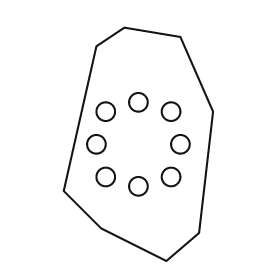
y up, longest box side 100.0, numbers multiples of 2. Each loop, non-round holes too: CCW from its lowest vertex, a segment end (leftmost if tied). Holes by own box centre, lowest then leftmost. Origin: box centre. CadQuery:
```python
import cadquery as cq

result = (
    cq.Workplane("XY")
    .moveTo(12.0, -50.0)
    .lineTo(26.0, -38.0)
    .lineTo(32.0, 14.0)
    .lineTo(18.0, 46.0)
    .lineTo(-6.0, 50.0)
    .lineTo(-18.0, 42.0)
    .lineTo(-32.0, -20.0)
    .lineTo(-16.0, -36.0)
    .close()
    .moveTo(0.0, -18.0)
    .circle(4.0)
    .moveTo(-14.0, -14.0)
    .circle(4.0)
    .moveTo(14.0, -14.0)
    .circle(4.0)
    .moveTo(-18.0, 0.0)
    .circle(4.0)
    .moveTo(18.0, 0.0)
    .circle(4.0)
    .moveTo(-14.0, 14.0)
    .circle(4.0)
    .moveTo(14.0, 14.0)
    .circle(4.0)
    .moveTo(0.0, 18.0)
    .circle(4.0)
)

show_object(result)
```